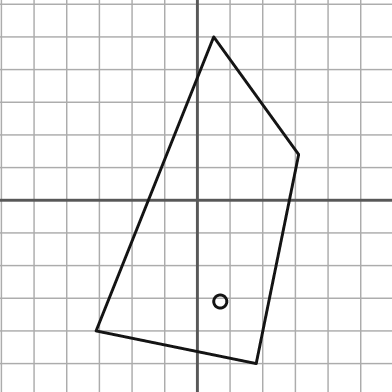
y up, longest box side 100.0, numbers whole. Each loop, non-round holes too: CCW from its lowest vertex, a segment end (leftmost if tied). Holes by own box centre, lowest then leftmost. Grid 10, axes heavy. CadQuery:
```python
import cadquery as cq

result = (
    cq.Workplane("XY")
    .moveTo(18.0, -50.0)
    .lineTo(31.0, 14.0)
    .lineTo(5.0, 50.0)
    .lineTo(-31.0, -40.0)
    .close()
    .moveTo(7.0, -31.0)
    .circle(2.0)
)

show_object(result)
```